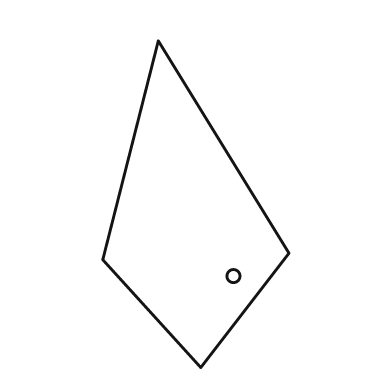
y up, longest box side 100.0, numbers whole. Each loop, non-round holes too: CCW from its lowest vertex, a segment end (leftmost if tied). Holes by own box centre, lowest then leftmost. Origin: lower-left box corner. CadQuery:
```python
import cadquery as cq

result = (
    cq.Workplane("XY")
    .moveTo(30.0, 0.0)
    .lineTo(57.0, 35.0)
    .lineTo(17.0, 100.0)
    .lineTo(0.0, 33.0)
    .close()
    .moveTo(40.0, 28.0)
    .circle(2.0)
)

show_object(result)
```